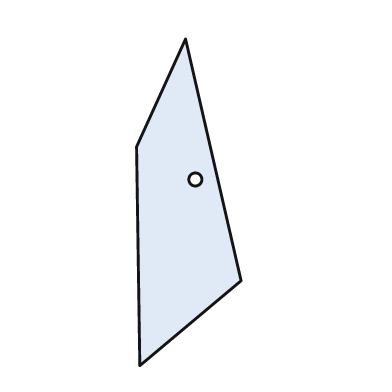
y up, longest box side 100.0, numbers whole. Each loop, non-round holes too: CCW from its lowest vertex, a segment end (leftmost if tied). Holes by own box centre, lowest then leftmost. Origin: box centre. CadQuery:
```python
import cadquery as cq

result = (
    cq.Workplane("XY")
    .moveTo(-15.0, -50.0)
    .lineTo(16.0, -24.0)
    .lineTo(-1.0, 50.0)
    .lineTo(-16.0, 17.0)
    .close()
    .moveTo(2.0, 7.0)
    .circle(2.0)
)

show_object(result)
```